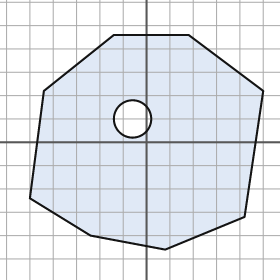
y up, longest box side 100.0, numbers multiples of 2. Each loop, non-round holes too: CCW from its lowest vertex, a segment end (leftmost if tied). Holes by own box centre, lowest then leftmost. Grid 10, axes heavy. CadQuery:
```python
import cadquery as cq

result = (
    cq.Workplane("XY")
    .moveTo(8.0, -46.0)
    .lineTo(42.0, -32.0)
    .lineTo(50.0, 22.0)
    .lineTo(18.0, 46.0)
    .lineTo(-14.0, 46.0)
    .lineTo(-44.0, 22.0)
    .lineTo(-50.0, -24.0)
    .lineTo(-24.0, -40.0)
    .close()
    .moveTo(-6.0, 10.0)
    .circle(8.0)
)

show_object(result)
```